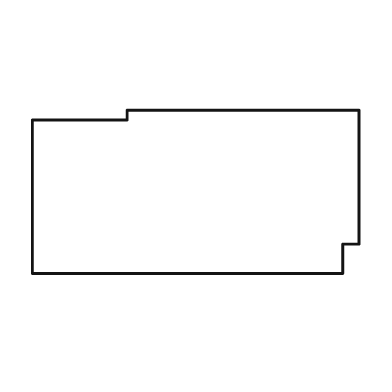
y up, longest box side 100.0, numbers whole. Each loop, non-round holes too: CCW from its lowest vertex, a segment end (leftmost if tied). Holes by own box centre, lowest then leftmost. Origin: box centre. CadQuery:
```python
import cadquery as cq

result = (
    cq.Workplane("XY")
    .moveTo(-50.0, -25.0)
    .lineTo(45.0, -25.0)
    .lineTo(45.0, -16.0)
    .lineTo(50.0, -16.0)
    .lineTo(50.0, 25.0)
    .lineTo(-21.0, 25.0)
    .lineTo(-21.0, 22.0)
    .lineTo(-50.0, 22.0)
    .close()
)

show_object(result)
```